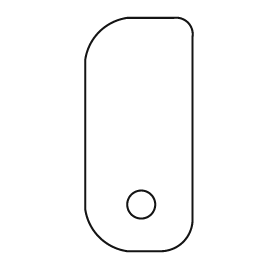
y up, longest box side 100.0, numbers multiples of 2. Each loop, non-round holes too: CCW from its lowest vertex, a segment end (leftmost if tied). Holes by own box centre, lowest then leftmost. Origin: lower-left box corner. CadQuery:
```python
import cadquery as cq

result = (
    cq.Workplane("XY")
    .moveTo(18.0, 0.0)
    .lineTo(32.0, 0.0)
    .threePointArc((42.0, 4.0), (46.0, 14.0))
    .lineTo(46.0, 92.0)
    .threePointArc((44.0, 98.0), (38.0, 100.0))
    .lineTo(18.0, 100.0)
    .threePointArc((6.0, 94.0), (0.0, 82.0))
    .lineTo(0.0, 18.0)
    .threePointArc((6.0, 6.0), (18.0, 0.0))
    .close()
    .moveTo(24.0, 20.0)
    .circle(6.0)
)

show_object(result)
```